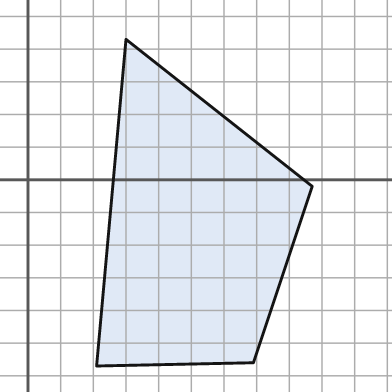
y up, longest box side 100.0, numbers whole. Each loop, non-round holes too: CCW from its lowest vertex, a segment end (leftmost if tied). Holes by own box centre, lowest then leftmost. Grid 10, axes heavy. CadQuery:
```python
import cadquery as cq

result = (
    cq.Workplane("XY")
    .moveTo(21.0, -57.0)
    .lineTo(69.0, -56.0)
    .lineTo(87.0, -2.0)
    .lineTo(30.0, 43.0)
    .close()
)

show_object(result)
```